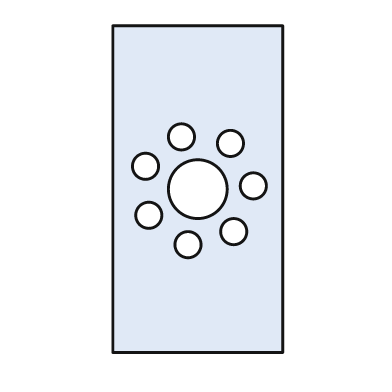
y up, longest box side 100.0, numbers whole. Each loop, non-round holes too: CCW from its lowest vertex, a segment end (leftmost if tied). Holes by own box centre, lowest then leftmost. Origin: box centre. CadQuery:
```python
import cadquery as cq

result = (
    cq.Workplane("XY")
    .moveTo(-26.0, -50.0)
    .lineTo(26.0, -50.0)
    .lineTo(26.0, 50.0)
    .lineTo(-26.0, 50.0)
    .close()
    .moveTo(-3.0, -17.0)
    .circle(4.0)
    .moveTo(11.0, -13.0)
    .circle(4.0)
    .moveTo(-15.0, -8.0)
    .circle(4.0)
    .moveTo(0.0, 0.0)
    .circle(9.0)
    .moveTo(17.0, 1.0)
    .circle(4.0)
    .moveTo(-16.0, 7.0)
    .circle(4.0)
    .moveTo(10.0, 14.0)
    .circle(4.0)
    .moveTo(-5.0, 16.0)
    .circle(4.0)
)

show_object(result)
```